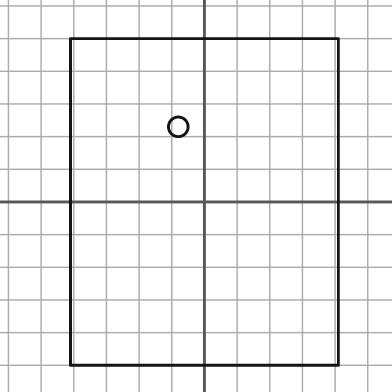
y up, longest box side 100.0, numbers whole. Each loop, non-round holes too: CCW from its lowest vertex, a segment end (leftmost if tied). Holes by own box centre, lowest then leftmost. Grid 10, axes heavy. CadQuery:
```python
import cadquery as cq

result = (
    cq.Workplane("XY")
    .moveTo(-41.0, -50.0)
    .lineTo(41.0, -50.0)
    .lineTo(41.0, 50.0)
    .lineTo(-41.0, 50.0)
    .close()
    .moveTo(-8.0, 23.0)
    .circle(3.0)
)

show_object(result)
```